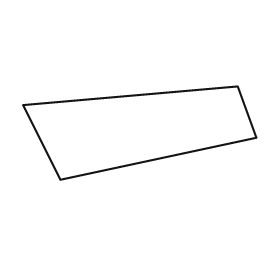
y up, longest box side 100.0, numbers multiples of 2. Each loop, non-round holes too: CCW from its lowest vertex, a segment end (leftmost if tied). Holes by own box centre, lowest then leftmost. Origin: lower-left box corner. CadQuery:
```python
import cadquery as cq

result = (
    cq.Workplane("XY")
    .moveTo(16.0, 0.0)
    .lineTo(100.0, 18.0)
    .lineTo(92.0, 40.0)
    .lineTo(0.0, 32.0)
    .close()
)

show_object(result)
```